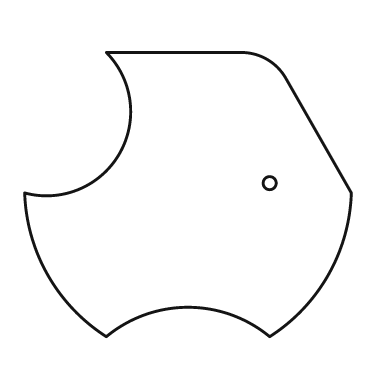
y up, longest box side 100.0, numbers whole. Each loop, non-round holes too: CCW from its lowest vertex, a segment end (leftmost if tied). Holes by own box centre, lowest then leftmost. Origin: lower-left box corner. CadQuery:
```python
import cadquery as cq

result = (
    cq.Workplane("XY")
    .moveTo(25.0, 0.0)
    .threePointArc((50.0, 9.0), (75.0, 0.0))
    .threePointArc((93.0, 19.0), (100.0, 44.0))
    .lineTo(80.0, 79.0)
    .threePointArc((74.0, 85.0), (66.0, 87.0))
    .lineTo(25.0, 87.0)
    .threePointArc((29.0, 56.0), (0.0, 44.0))
    .threePointArc((7.0, 19.0), (25.0, 0.0))
    .close()
    .moveTo(75.0, 47.0)
    .circle(2.0)
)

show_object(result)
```